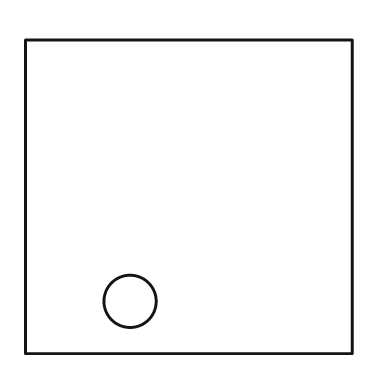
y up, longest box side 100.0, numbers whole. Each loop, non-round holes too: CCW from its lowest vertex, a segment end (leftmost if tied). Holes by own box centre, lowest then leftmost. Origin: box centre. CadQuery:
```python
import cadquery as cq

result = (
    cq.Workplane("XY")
    .moveTo(-50.0, -48.0)
    .lineTo(50.0, -48.0)
    .lineTo(50.0, 48.0)
    .lineTo(-50.0, 48.0)
    .close()
    .moveTo(-18.0, -32.0)
    .circle(8.0)
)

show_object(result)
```